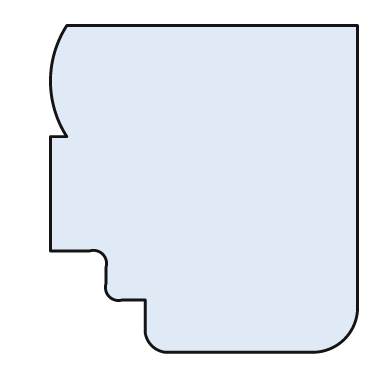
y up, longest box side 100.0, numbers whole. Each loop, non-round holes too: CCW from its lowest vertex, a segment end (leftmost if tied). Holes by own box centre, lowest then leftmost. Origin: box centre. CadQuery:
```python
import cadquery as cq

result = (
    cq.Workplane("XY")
    .moveTo(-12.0, -50.0)
    .lineTo(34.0, -50.0)
    .threePointArc((43.0, -46.0), (47.0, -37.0))
    .lineTo(47.0, 50.0)
    .lineTo(-42.0, 50.0)
    .threePointArc((-47.0, 33.0), (-42.0, 16.0))
    .lineTo(-47.0, 16.0)
    .lineTo(-47.0, -19.0)
    .lineTo(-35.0, -19.0)
    .threePointArc((-31.0, -20.0), (-30.0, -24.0))
    .lineTo(-30.0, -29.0)
    .threePointArc((-29.0, -33.0), (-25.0, -34.0))
    .lineTo(-18.0, -34.0)
    .lineTo(-18.0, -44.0)
    .threePointArc((-16.0, -48.0), (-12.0, -50.0))
    .close()
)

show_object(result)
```